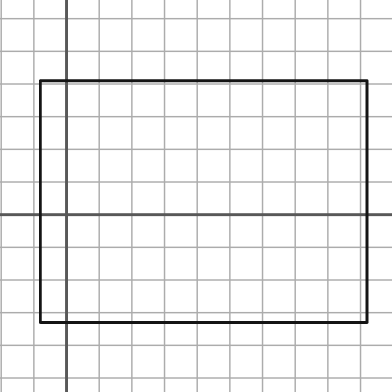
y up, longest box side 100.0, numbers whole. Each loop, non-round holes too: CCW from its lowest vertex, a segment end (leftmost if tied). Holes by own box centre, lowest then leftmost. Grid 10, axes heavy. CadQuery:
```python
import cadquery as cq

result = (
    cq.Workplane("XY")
    .moveTo(-8.0, -33.0)
    .lineTo(92.0, -33.0)
    .lineTo(92.0, 41.0)
    .lineTo(-8.0, 41.0)
    .close()
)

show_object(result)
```